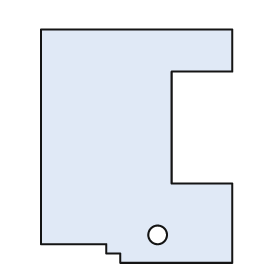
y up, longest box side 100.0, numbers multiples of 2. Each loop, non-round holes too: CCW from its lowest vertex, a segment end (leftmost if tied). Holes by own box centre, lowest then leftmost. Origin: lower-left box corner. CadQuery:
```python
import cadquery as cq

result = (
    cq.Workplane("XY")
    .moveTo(34.0, 0.0)
    .lineTo(82.0, 0.0)
    .lineTo(82.0, 34.0)
    .lineTo(56.0, 34.0)
    .lineTo(56.0, 82.0)
    .lineTo(82.0, 82.0)
    .lineTo(82.0, 100.0)
    .lineTo(0.0, 100.0)
    .lineTo(0.0, 8.0)
    .lineTo(28.0, 8.0)
    .lineTo(28.0, 4.0)
    .lineTo(34.0, 4.0)
    .close()
    .moveTo(50.0, 12.0)
    .circle(4.0)
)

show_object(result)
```